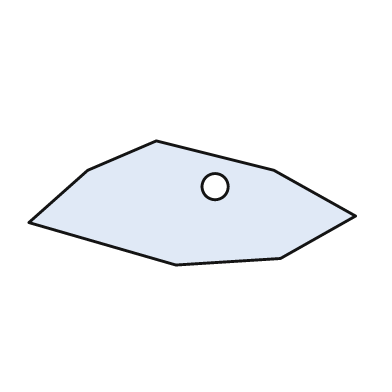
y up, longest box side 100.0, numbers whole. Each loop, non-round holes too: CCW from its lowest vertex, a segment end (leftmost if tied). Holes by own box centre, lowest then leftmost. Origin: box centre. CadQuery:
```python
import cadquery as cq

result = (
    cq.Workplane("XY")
    .moveTo(-5.0, -19.0)
    .lineTo(27.0, -17.0)
    .lineTo(50.0, -4.0)
    .lineTo(25.0, 10.0)
    .lineTo(-11.0, 19.0)
    .lineTo(-32.0, 10.0)
    .lineTo(-50.0, -6.0)
    .close()
    .moveTo(7.0, 5.0)
    .circle(4.0)
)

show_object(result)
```